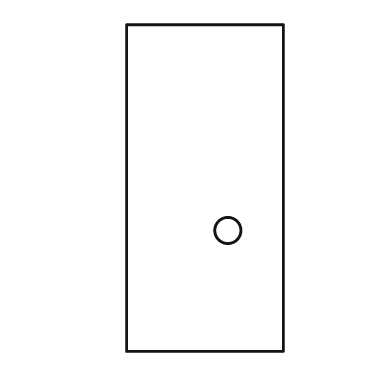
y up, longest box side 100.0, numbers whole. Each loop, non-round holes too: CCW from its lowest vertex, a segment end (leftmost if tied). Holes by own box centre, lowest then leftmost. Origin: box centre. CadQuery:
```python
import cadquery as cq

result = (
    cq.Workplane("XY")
    .moveTo(-24.0, -50.0)
    .lineTo(24.0, -50.0)
    .lineTo(24.0, 50.0)
    .lineTo(-24.0, 50.0)
    .close()
    .moveTo(7.0, -13.0)
    .circle(4.0)
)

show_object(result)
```